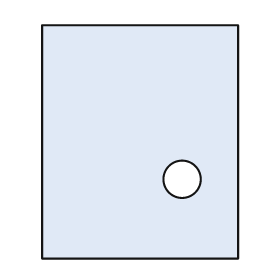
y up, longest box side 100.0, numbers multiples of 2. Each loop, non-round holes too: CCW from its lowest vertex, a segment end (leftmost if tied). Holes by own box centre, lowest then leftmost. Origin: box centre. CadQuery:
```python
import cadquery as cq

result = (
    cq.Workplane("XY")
    .moveTo(-42.0, -50.0)
    .lineTo(42.0, -50.0)
    .lineTo(42.0, 50.0)
    .lineTo(-42.0, 50.0)
    .close()
    .moveTo(18.0, -16.0)
    .circle(8.0)
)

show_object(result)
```